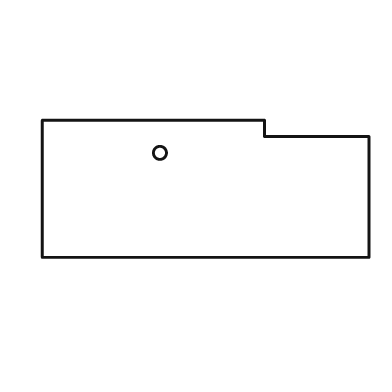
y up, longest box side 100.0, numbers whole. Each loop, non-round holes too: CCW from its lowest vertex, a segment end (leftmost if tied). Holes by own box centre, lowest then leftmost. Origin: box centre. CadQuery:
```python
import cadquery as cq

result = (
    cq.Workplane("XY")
    .moveTo(-50.0, -21.0)
    .lineTo(50.0, -21.0)
    .lineTo(50.0, 16.0)
    .lineTo(18.0, 16.0)
    .lineTo(18.0, 21.0)
    .lineTo(-50.0, 21.0)
    .close()
    .moveTo(-14.0, 11.0)
    .circle(2.0)
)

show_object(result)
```